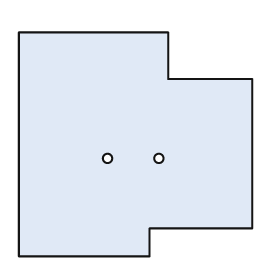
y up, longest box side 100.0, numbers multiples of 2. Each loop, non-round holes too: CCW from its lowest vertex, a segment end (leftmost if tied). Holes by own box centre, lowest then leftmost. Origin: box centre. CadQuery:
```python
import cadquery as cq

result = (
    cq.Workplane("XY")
    .moveTo(-50.0, -48.0)
    .lineTo(6.0, -48.0)
    .lineTo(6.0, -36.0)
    .lineTo(50.0, -36.0)
    .lineTo(50.0, 28.0)
    .lineTo(14.0, 28.0)
    .lineTo(14.0, 48.0)
    .lineTo(-50.0, 48.0)
    .close()
    .moveTo(-12.0, -6.0)
    .circle(2.0)
    .moveTo(10.0, -6.0)
    .circle(2.0)
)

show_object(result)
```